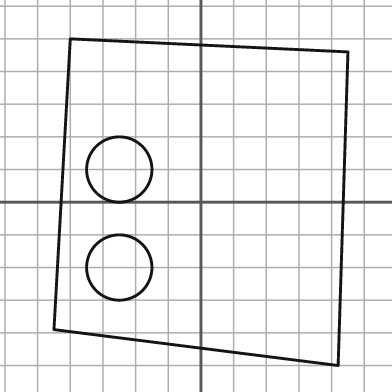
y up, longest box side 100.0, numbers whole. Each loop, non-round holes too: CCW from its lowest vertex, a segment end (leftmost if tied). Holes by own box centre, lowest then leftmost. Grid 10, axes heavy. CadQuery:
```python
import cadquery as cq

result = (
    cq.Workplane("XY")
    .moveTo(42.0, -50.0)
    .lineTo(45.0, 46.0)
    .lineTo(-40.0, 50.0)
    .lineTo(-45.0, -39.0)
    .close()
    .moveTo(-25.0, -20.0)
    .circle(10.0)
    .moveTo(-25.0, 10.0)
    .circle(10.0)
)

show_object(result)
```